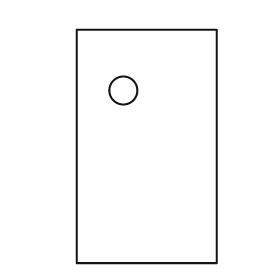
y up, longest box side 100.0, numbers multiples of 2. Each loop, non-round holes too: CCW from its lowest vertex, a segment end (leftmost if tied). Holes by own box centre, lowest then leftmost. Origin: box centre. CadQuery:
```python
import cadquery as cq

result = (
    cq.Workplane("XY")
    .moveTo(-30.0, -50.0)
    .lineTo(30.0, -50.0)
    .lineTo(30.0, 50.0)
    .lineTo(-30.0, 50.0)
    .close()
    .moveTo(-10.0, 24.0)
    .circle(6.0)
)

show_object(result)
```